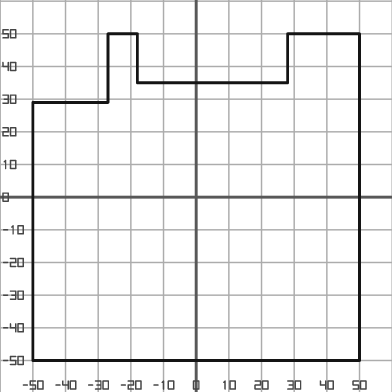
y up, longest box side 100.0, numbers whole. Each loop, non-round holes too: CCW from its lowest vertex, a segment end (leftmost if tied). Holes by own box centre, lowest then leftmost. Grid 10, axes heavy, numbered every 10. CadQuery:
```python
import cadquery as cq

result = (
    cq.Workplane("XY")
    .moveTo(-50.0, -50.0)
    .lineTo(50.0, -50.0)
    .lineTo(50.0, 50.0)
    .lineTo(28.0, 50.0)
    .lineTo(28.0, 35.0)
    .lineTo(-18.0, 35.0)
    .lineTo(-18.0, 50.0)
    .lineTo(-27.0, 50.0)
    .lineTo(-27.0, 29.0)
    .lineTo(-50.0, 29.0)
    .close()
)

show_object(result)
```